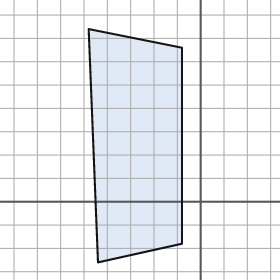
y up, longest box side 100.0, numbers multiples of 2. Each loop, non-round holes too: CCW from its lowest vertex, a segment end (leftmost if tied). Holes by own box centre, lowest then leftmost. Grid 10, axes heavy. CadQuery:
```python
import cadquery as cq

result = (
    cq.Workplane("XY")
    .moveTo(-44.0, -26.0)
    .lineTo(-8.0, -18.0)
    .lineTo(-8.0, 66.0)
    .lineTo(-48.0, 74.0)
    .close()
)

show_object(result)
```